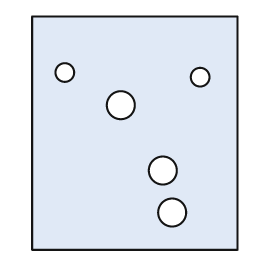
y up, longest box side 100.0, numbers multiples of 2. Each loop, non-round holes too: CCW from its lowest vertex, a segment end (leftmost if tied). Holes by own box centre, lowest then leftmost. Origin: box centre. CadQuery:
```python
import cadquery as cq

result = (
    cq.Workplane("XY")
    .moveTo(-44.0, -50.0)
    .lineTo(44.0, -50.0)
    .lineTo(44.0, 50.0)
    .lineTo(-44.0, 50.0)
    .close()
    .moveTo(16.0, -34.0)
    .circle(6.0)
    .moveTo(12.0, -16.0)
    .circle(6.0)
    .moveTo(-6.0, 12.0)
    .circle(6.0)
    .moveTo(28.0, 24.0)
    .circle(4.0)
    .moveTo(-30.0, 26.0)
    .circle(4.0)
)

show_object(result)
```